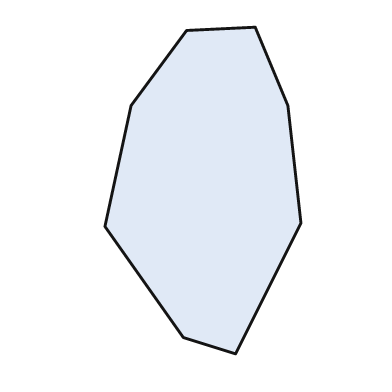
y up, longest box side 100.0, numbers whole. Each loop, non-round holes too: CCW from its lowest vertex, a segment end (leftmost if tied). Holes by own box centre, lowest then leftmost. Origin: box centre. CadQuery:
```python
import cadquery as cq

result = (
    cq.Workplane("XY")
    .moveTo(10.0, -50.0)
    .lineTo(30.0, -10.0)
    .lineTo(26.0, 26.0)
    .lineTo(16.0, 50.0)
    .lineTo(-5.0, 49.0)
    .lineTo(-22.0, 26.0)
    .lineTo(-30.0, -11.0)
    .lineTo(-6.0, -45.0)
    .close()
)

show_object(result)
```